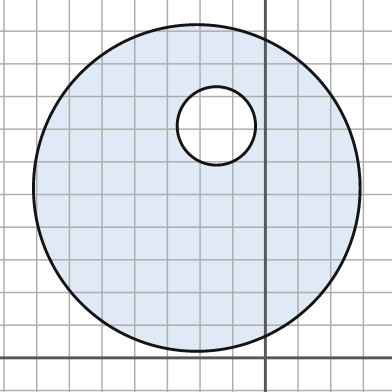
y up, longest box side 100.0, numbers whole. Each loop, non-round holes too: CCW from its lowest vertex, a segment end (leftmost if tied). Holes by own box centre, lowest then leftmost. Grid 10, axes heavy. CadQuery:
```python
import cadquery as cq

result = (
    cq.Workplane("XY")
    .moveTo(-21.0, 52.0)
    .circle(50.0)
    .moveTo(-15.0, 71.0)
    .circle(12.0)
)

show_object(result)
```